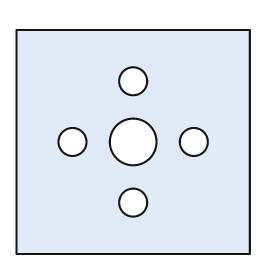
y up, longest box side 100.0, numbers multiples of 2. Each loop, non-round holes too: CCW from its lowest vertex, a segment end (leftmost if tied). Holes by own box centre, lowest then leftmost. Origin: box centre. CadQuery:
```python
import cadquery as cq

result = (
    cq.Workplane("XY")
    .moveTo(-50.0, -48.0)
    .lineTo(50.0, -48.0)
    .lineTo(50.0, 48.0)
    .lineTo(-50.0, 48.0)
    .close()
    .moveTo(0.0, -26.0)
    .circle(6.0)
    .moveTo(-26.0, 0.0)
    .circle(6.0)
    .moveTo(0.0, 0.0)
    .circle(10.0)
    .moveTo(26.0, 0.0)
    .circle(6.0)
    .moveTo(0.0, 26.0)
    .circle(6.0)
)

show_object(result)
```